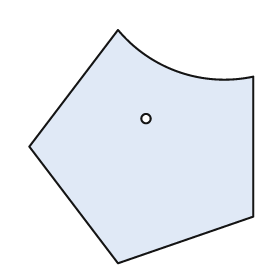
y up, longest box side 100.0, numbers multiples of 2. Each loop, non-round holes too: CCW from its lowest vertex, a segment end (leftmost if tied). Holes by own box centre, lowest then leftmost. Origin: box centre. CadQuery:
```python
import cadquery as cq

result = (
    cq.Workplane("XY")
    .moveTo(-10.0, -50.0)
    .lineTo(48.0, -30.0)
    .lineTo(48.0, 30.0)
    .threePointArc((16.0, 32.0), (-10.0, 50.0))
    .lineTo(-48.0, 0.0)
    .close()
    .moveTo(2.0, 12.0)
    .circle(2.0)
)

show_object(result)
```